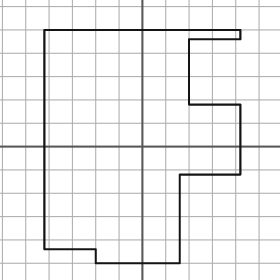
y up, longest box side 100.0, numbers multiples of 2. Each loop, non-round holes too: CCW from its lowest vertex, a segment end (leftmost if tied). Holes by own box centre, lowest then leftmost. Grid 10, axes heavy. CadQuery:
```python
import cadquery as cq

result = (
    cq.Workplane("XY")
    .moveTo(-20.0, -50.0)
    .lineTo(16.0, -50.0)
    .lineTo(16.0, -12.0)
    .lineTo(42.0, -12.0)
    .lineTo(42.0, 18.0)
    .lineTo(20.0, 18.0)
    .lineTo(20.0, 46.0)
    .lineTo(42.0, 46.0)
    .lineTo(42.0, 50.0)
    .lineTo(-42.0, 50.0)
    .lineTo(-42.0, -44.0)
    .lineTo(-20.0, -44.0)
    .close()
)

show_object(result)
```